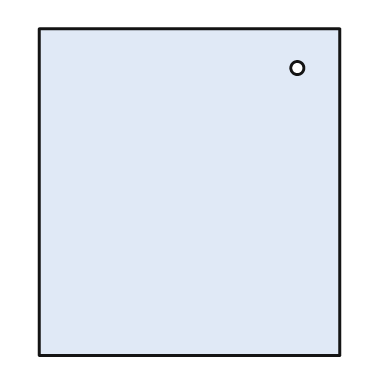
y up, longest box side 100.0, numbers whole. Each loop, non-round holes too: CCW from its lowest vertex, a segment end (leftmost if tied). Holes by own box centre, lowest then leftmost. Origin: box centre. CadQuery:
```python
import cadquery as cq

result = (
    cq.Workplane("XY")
    .moveTo(-46.0, -50.0)
    .lineTo(46.0, -50.0)
    .lineTo(46.0, 50.0)
    .lineTo(-46.0, 50.0)
    .close()
    .moveTo(33.0, 38.0)
    .circle(2.0)
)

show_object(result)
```